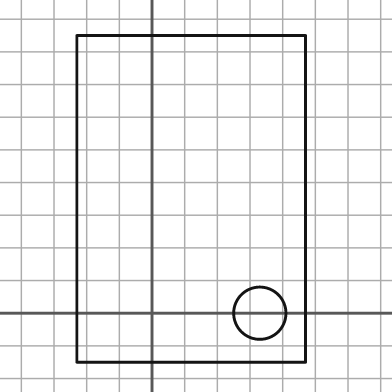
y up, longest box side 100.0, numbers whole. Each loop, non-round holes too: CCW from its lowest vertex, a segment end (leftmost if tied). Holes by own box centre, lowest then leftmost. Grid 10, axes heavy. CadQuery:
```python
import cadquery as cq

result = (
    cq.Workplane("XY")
    .moveTo(-23.0, -15.0)
    .lineTo(47.0, -15.0)
    .lineTo(47.0, 85.0)
    .lineTo(-23.0, 85.0)
    .close()
    .moveTo(33.0, 0.0)
    .circle(8.0)
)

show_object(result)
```